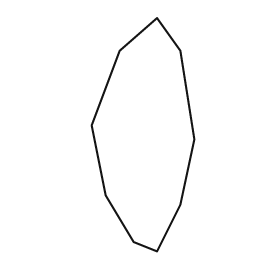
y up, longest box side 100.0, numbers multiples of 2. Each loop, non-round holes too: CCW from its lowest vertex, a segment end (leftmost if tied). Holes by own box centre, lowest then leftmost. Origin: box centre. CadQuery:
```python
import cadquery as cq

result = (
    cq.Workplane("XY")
    .moveTo(6.0, -50.0)
    .lineTo(16.0, -30.0)
    .lineTo(22.0, -2.0)
    .lineTo(16.0, 36.0)
    .lineTo(6.0, 50.0)
    .lineTo(-10.0, 36.0)
    .lineTo(-22.0, 4.0)
    .lineTo(-16.0, -26.0)
    .lineTo(-4.0, -46.0)
    .close()
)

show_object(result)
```